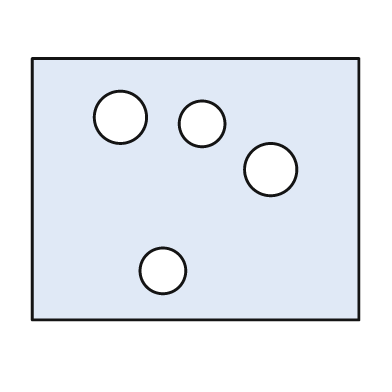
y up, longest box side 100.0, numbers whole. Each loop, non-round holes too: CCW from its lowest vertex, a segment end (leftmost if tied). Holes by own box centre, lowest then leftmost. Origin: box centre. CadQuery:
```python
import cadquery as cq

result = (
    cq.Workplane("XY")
    .moveTo(-50.0, -40.0)
    .lineTo(50.0, -40.0)
    .lineTo(50.0, 40.0)
    .lineTo(-50.0, 40.0)
    .close()
    .moveTo(-10.0, -25.0)
    .circle(7.0)
    .moveTo(23.0, 6.0)
    .circle(8.0)
    .moveTo(2.0, 20.0)
    .circle(7.0)
    .moveTo(-23.0, 22.0)
    .circle(8.0)
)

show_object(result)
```